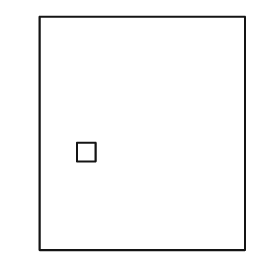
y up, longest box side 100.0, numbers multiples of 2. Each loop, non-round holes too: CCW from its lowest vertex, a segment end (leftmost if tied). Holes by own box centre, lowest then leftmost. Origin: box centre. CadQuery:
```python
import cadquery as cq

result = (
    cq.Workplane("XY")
    .moveTo(-44.0, -50.0)
    .lineTo(44.0, -50.0)
    .lineTo(44.0, 50.0)
    .lineTo(-44.0, 50.0)
    .close()
    .moveTo(-28.0, -12.0)
    .lineTo(-20.0, -12.0)
    .lineTo(-20.0, -4.0)
    .lineTo(-28.0, -4.0)
    .close()
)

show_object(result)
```